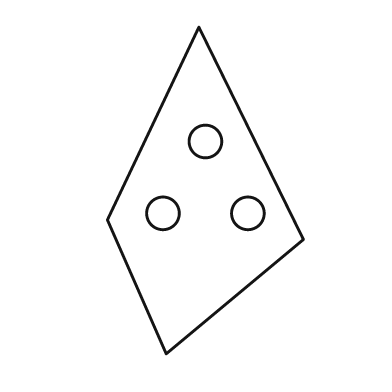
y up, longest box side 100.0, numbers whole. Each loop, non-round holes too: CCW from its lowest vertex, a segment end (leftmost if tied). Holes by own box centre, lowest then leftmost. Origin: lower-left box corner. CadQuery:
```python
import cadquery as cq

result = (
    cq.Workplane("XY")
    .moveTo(18.0, 0.0)
    .lineTo(60.0, 35.0)
    .lineTo(28.0, 100.0)
    .lineTo(0.0, 41.0)
    .close()
    .moveTo(17.0, 43.0)
    .circle(5.0)
    .moveTo(43.0, 43.0)
    .circle(5.0)
    .moveTo(30.0, 65.0)
    .circle(5.0)
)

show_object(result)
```